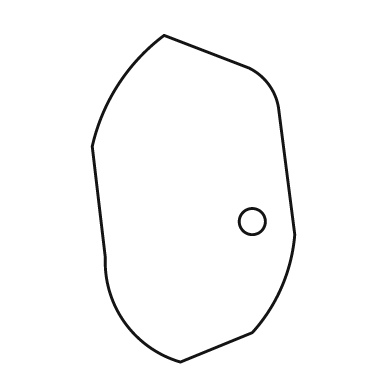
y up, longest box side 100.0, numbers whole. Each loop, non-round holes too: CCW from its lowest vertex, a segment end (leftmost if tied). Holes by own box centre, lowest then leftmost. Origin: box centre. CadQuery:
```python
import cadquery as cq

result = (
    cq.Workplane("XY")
    .moveTo(-4.0, -50.0)
    .lineTo(18.0, -41.0)
    .threePointArc((27.0, -27.0), (31.0, -11.0))
    .lineTo(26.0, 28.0)
    .threePointArc((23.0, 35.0), (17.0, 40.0))
    .lineTo(-9.0, 50.0)
    .threePointArc((-23.0, 35.0), (-31.0, 16.0))
    .lineTo(-27.0, -18.0)
    .threePointArc((-21.0, -38.0), (-4.0, -50.0))
    .close()
    .moveTo(18.0, -7.0)
    .circle(4.0)
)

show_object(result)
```